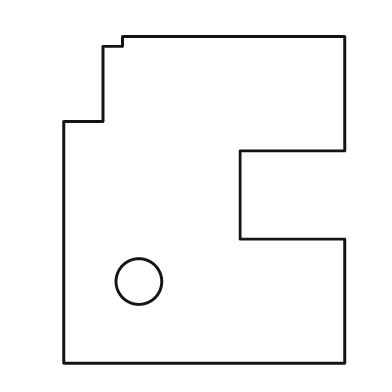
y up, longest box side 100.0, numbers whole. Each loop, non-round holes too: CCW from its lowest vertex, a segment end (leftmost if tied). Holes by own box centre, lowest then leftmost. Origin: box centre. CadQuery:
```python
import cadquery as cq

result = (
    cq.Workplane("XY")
    .moveTo(-43.0, -50.0)
    .lineTo(43.0, -50.0)
    .lineTo(43.0, -12.0)
    .lineTo(11.0, -12.0)
    .lineTo(11.0, 15.0)
    .lineTo(43.0, 15.0)
    .lineTo(43.0, 50.0)
    .lineTo(-25.0, 50.0)
    .lineTo(-25.0, 47.0)
    .lineTo(-31.0, 47.0)
    .lineTo(-31.0, 24.0)
    .lineTo(-43.0, 24.0)
    .close()
    .moveTo(-20.0, -25.0)
    .circle(7.0)
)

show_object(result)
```